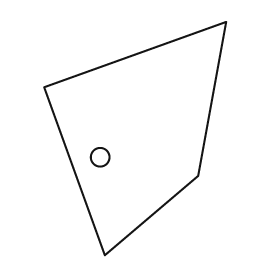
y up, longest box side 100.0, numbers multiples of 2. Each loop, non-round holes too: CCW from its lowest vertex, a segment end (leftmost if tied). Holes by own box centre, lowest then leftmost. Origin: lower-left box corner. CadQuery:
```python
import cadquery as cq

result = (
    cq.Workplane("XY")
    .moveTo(26.0, 0.0)
    .lineTo(66.0, 34.0)
    .lineTo(78.0, 100.0)
    .lineTo(0.0, 72.0)
    .close()
    .moveTo(24.0, 42.0)
    .circle(4.0)
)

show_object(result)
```